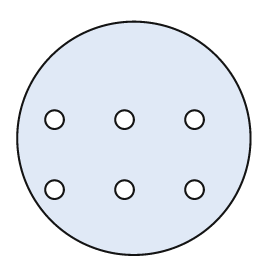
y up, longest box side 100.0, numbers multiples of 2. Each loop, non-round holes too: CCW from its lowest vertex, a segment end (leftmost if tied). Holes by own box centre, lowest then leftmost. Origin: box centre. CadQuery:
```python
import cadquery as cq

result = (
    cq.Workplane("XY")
    .moveTo(0.0, 0.0)
    .circle(50.0)
    .moveTo(-34.0, -22.0)
    .circle(4.0)
    .moveTo(-4.0, -22.0)
    .circle(4.0)
    .moveTo(26.0, -22.0)
    .circle(4.0)
    .moveTo(-34.0, 8.0)
    .circle(4.0)
    .moveTo(-4.0, 8.0)
    .circle(4.0)
    .moveTo(26.0, 8.0)
    .circle(4.0)
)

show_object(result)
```